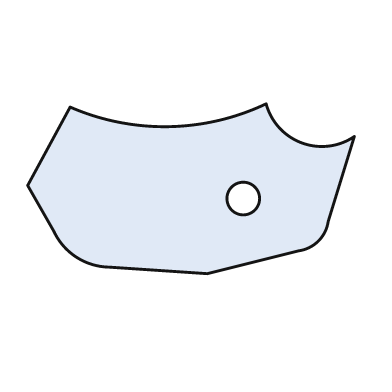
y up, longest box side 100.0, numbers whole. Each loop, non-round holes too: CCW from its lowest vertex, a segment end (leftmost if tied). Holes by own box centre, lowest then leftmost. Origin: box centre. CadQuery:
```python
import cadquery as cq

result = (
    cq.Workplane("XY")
    .moveTo(5.0, -26.0)
    .lineTo(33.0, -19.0)
    .threePointArc((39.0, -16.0), (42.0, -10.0))
    .lineTo(50.0, 16.0)
    .threePointArc((34.0, 14.0), (23.0, 26.0))
    .threePointArc((-7.0, 19.0), (-37.0, 25.0))
    .lineTo(-50.0, 1.0)
    .lineTo(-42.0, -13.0)
    .threePointArc((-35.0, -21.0), (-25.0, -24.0))
    .close()
    .moveTo(16.0, -3.0)
    .circle(5.0)
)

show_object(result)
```